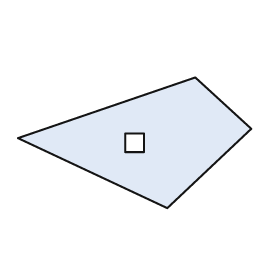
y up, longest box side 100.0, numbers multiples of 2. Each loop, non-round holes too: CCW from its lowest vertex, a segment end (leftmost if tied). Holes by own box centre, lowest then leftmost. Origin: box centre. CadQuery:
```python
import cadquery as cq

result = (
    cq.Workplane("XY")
    .moveTo(14.0, -28.0)
    .lineTo(50.0, 6.0)
    .lineTo(26.0, 28.0)
    .lineTo(-50.0, 2.0)
    .close()
    .moveTo(-4.0, -4.0)
    .lineTo(4.0, -4.0)
    .lineTo(4.0, 4.0)
    .lineTo(-4.0, 4.0)
    .close()
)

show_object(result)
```